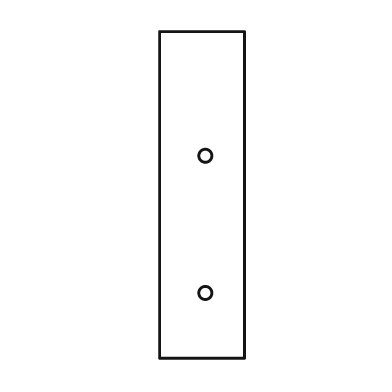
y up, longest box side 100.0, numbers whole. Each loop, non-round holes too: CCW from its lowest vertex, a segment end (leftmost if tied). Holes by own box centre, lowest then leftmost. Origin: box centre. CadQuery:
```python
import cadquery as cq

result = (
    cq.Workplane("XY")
    .moveTo(-13.0, -50.0)
    .lineTo(13.0, -50.0)
    .lineTo(13.0, 50.0)
    .lineTo(-13.0, 50.0)
    .close()
    .moveTo(1.0, -30.0)
    .circle(2.0)
    .moveTo(1.0, 12.0)
    .circle(2.0)
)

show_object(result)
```